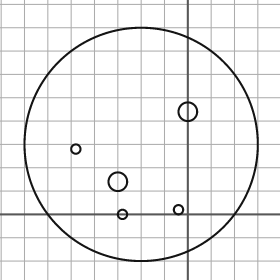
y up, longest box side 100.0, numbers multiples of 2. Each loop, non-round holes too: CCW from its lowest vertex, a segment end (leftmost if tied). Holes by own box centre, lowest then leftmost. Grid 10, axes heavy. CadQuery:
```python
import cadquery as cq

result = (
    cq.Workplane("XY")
    .moveTo(-20.0, 30.0)
    .circle(50.0)
    .moveTo(-28.0, 0.0)
    .circle(2.0)
    .moveTo(-4.0, 2.0)
    .circle(2.0)
    .moveTo(-30.0, 14.0)
    .circle(4.0)
    .moveTo(-48.0, 28.0)
    .circle(2.0)
    .moveTo(0.0, 44.0)
    .circle(4.0)
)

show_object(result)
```